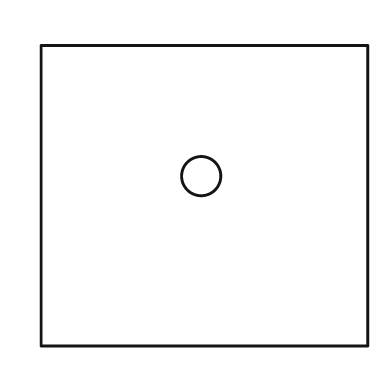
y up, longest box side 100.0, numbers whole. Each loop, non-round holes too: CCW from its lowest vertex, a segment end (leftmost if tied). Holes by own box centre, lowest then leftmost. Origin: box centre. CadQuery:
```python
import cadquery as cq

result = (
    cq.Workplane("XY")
    .moveTo(-50.0, -46.0)
    .lineTo(50.0, -46.0)
    .lineTo(50.0, 46.0)
    .lineTo(-50.0, 46.0)
    .close()
    .moveTo(-1.0, 6.0)
    .circle(6.0)
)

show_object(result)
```